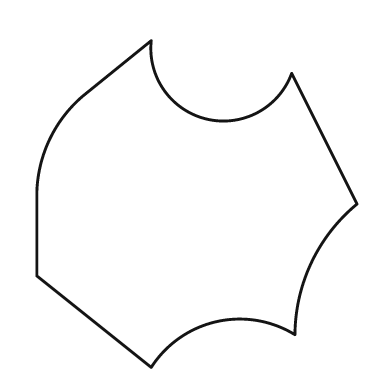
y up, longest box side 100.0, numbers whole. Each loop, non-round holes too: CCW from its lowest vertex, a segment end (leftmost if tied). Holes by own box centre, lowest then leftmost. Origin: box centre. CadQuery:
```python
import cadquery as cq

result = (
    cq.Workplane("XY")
    .moveTo(-14.0, -50.0)
    .threePointArc((6.0, -36.0), (30.0, -40.0))
    .threePointArc((35.0, -18.0), (49.0, 0.0))
    .lineTo(29.0, 40.0)
    .threePointArc((3.0, 26.0), (-14.0, 50.0))
    .lineTo(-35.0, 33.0)
    .threePointArc((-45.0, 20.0), (-49.0, 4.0))
    .lineTo(-49.0, -22.0)
    .close()
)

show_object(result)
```